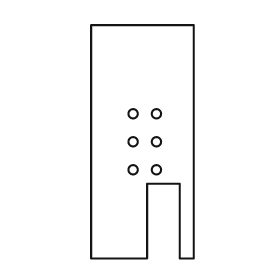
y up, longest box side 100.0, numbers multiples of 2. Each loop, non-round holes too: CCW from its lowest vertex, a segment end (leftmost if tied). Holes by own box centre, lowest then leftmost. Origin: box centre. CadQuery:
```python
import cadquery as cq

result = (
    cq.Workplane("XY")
    .moveTo(-22.0, -50.0)
    .lineTo(2.0, -50.0)
    .lineTo(2.0, -18.0)
    .lineTo(16.0, -18.0)
    .lineTo(16.0, -50.0)
    .lineTo(22.0, -50.0)
    .lineTo(22.0, 50.0)
    .lineTo(-22.0, 50.0)
    .close()
    .moveTo(-4.0, -12.0)
    .circle(2.0)
    .moveTo(6.0, -12.0)
    .circle(2.0)
    .moveTo(-4.0, 0.0)
    .circle(2.0)
    .moveTo(6.0, 0.0)
    .circle(2.0)
    .moveTo(-4.0, 12.0)
    .circle(2.0)
    .moveTo(6.0, 12.0)
    .circle(2.0)
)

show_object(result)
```